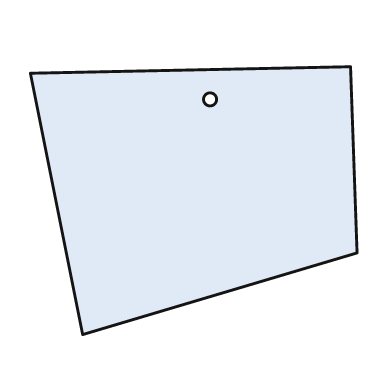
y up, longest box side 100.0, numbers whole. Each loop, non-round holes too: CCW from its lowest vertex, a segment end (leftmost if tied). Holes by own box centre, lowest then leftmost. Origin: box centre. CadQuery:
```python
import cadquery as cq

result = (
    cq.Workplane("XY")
    .moveTo(-34.0, -41.0)
    .lineTo(50.0, -16.0)
    .lineTo(48.0, 41.0)
    .lineTo(-50.0, 39.0)
    .close()
    .moveTo(5.0, 31.0)
    .circle(2.0)
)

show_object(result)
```